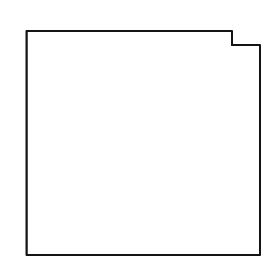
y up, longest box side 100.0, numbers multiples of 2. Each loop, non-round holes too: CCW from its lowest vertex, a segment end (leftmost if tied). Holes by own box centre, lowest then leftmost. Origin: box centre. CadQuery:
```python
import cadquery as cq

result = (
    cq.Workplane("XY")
    .moveTo(-50.0, -48.0)
    .lineTo(50.0, -48.0)
    .lineTo(50.0, 42.0)
    .lineTo(38.0, 42.0)
    .lineTo(38.0, 48.0)
    .lineTo(-50.0, 48.0)
    .close()
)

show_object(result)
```